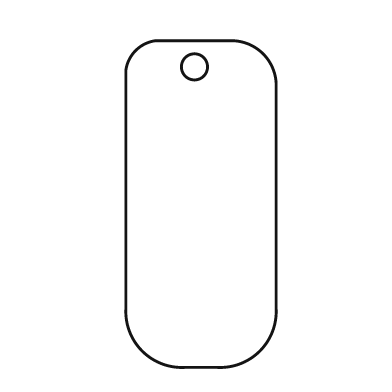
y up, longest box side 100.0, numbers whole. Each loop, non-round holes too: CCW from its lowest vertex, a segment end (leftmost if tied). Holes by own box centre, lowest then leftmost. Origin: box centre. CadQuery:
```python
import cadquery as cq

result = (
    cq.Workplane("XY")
    .moveTo(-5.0, -50.0)
    .lineTo(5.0, -50.0)
    .threePointArc((18.0, -45.0), (23.0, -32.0))
    .lineTo(23.0, 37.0)
    .threePointArc((19.0, 46.0), (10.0, 50.0))
    .lineTo(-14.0, 50.0)
    .threePointArc((-20.0, 47.0), (-23.0, 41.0))
    .lineTo(-23.0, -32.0)
    .threePointArc((-18.0, -45.0), (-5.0, -50.0))
    .close()
    .moveTo(-2.0, 42.0)
    .circle(4.0)
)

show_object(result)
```